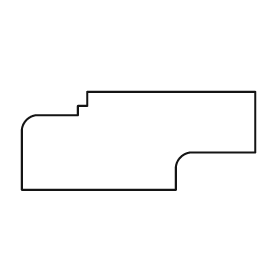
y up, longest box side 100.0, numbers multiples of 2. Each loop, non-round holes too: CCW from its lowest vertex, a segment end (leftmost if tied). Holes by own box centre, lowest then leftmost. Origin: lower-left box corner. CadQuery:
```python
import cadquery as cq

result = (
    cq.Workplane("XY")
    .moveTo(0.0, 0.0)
    .lineTo(66.0, 0.0)
    .lineTo(66.0, 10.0)
    .threePointArc((68.0, 14.0), (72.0, 16.0))
    .lineTo(100.0, 16.0)
    .lineTo(100.0, 42.0)
    .lineTo(28.0, 42.0)
    .lineTo(28.0, 36.0)
    .lineTo(24.0, 36.0)
    .lineTo(24.0, 32.0)
    .lineTo(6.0, 32.0)
    .threePointArc((2.0, 30.0), (0.0, 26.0))
    .close()
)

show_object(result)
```